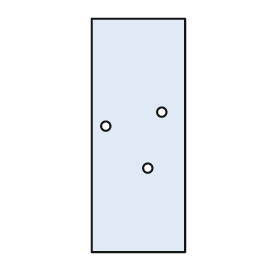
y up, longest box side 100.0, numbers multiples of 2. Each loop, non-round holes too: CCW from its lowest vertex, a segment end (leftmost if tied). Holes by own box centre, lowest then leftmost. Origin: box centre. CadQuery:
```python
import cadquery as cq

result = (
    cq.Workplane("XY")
    .moveTo(-20.0, -50.0)
    .lineTo(20.0, -50.0)
    .lineTo(20.0, 50.0)
    .lineTo(-20.0, 50.0)
    .close()
    .moveTo(4.0, -14.0)
    .circle(2.0)
    .moveTo(-14.0, 4.0)
    .circle(2.0)
    .moveTo(10.0, 10.0)
    .circle(2.0)
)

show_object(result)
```